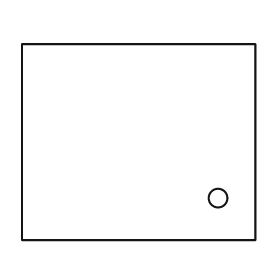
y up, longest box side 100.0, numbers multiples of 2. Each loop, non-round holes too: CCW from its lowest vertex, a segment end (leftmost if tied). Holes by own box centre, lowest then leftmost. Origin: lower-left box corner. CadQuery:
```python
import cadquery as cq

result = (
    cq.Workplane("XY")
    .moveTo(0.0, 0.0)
    .lineTo(100.0, 0.0)
    .lineTo(100.0, 84.0)
    .lineTo(0.0, 84.0)
    .close()
    .moveTo(84.0, 18.0)
    .circle(4.0)
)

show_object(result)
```